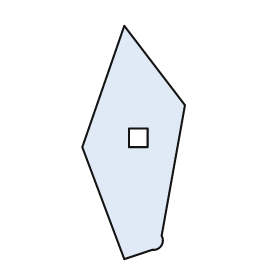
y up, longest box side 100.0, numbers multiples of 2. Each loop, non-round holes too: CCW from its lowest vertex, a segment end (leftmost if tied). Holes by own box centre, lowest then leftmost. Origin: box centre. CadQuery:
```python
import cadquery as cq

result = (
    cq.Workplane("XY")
    .moveTo(-4.0, -50.0)
    .lineTo(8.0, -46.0)
    .threePointArc((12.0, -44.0), (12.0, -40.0))
    .lineTo(22.0, 16.0)
    .lineTo(-4.0, 50.0)
    .lineTo(-22.0, -2.0)
    .close()
    .moveTo(-2.0, -2.0)
    .lineTo(6.0, -2.0)
    .lineTo(6.0, 6.0)
    .lineTo(-2.0, 6.0)
    .close()
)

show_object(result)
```